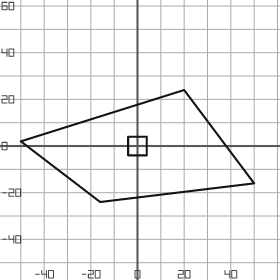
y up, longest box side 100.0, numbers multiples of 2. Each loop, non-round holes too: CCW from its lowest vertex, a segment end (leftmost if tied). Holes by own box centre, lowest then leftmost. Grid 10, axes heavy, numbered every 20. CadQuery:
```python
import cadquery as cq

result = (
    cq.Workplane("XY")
    .moveTo(-16.0, -24.0)
    .lineTo(50.0, -16.0)
    .lineTo(20.0, 24.0)
    .lineTo(-50.0, 2.0)
    .close()
    .moveTo(-4.0, -4.0)
    .lineTo(4.0, -4.0)
    .lineTo(4.0, 4.0)
    .lineTo(-4.0, 4.0)
    .close()
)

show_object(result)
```